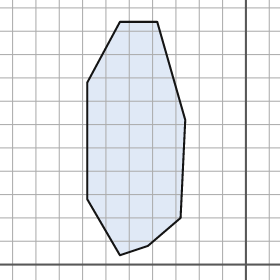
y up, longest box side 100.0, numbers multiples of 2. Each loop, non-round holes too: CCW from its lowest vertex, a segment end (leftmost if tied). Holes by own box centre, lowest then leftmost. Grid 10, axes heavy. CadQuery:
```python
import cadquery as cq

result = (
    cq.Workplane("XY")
    .moveTo(-54.0, 4.0)
    .lineTo(-42.0, 8.0)
    .lineTo(-28.0, 20.0)
    .lineTo(-26.0, 62.0)
    .lineTo(-38.0, 104.0)
    .lineTo(-54.0, 104.0)
    .lineTo(-68.0, 78.0)
    .lineTo(-68.0, 28.0)
    .close()
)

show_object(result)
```